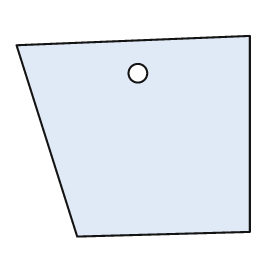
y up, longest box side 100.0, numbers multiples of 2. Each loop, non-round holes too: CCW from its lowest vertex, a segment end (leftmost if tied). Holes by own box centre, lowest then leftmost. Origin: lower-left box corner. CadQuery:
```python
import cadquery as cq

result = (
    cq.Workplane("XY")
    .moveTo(26.0, 0.0)
    .lineTo(100.0, 2.0)
    .lineTo(100.0, 86.0)
    .lineTo(0.0, 82.0)
    .close()
    .moveTo(52.0, 70.0)
    .circle(4.0)
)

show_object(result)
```